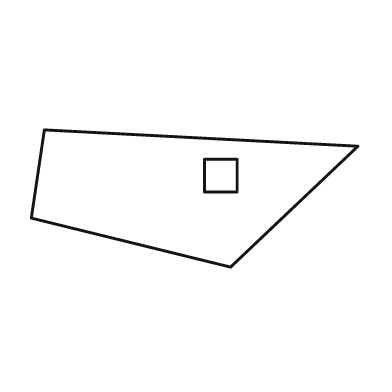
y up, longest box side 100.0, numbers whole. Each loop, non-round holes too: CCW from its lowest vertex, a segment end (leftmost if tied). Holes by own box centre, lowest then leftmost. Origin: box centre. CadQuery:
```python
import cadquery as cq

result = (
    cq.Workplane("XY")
    .moveTo(11.0, -21.0)
    .lineTo(50.0, 16.0)
    .lineTo(-46.0, 21.0)
    .lineTo(-50.0, -6.0)
    .close()
    .moveTo(3.0, 2.0)
    .lineTo(13.0, 2.0)
    .lineTo(13.0, 12.0)
    .lineTo(3.0, 12.0)
    .close()
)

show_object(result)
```